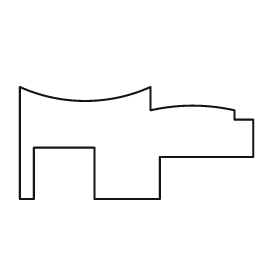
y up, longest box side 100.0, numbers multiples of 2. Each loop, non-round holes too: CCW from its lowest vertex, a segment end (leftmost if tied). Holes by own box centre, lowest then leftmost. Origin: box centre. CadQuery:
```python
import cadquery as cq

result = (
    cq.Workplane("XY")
    .moveTo(-50.0, -24.0)
    .lineTo(-44.0, -24.0)
    .lineTo(-44.0, -2.0)
    .lineTo(-18.0, -2.0)
    .lineTo(-18.0, -24.0)
    .lineTo(10.0, -24.0)
    .lineTo(10.0, -6.0)
    .lineTo(50.0, -6.0)
    .lineTo(50.0, 10.0)
    .lineTo(42.0, 10.0)
    .lineTo(42.0, 14.0)
    .threePointArc((24.0, 16.0), (6.0, 14.0))
    .lineTo(6.0, 24.0)
    .threePointArc((-22.0, 18.0), (-50.0, 24.0))
    .close()
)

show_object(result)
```